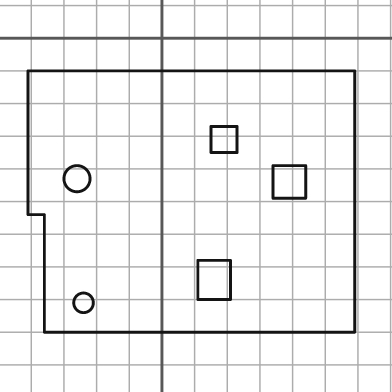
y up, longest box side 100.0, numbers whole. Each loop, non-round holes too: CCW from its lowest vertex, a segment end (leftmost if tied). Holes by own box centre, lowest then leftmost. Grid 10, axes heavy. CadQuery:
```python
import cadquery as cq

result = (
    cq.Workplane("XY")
    .moveTo(-36.0, -90.0)
    .lineTo(59.0, -90.0)
    .lineTo(59.0, -10.0)
    .lineTo(-41.0, -10.0)
    .lineTo(-41.0, -54.0)
    .lineTo(-36.0, -54.0)
    .close()
    .moveTo(-24.0, -81.0)
    .circle(3.0)
    .moveTo(11.0, -80.0)
    .lineTo(21.0, -80.0)
    .lineTo(21.0, -68.0)
    .lineTo(11.0, -68.0)
    .close()
    .moveTo(34.0, -49.0)
    .lineTo(44.0, -49.0)
    .lineTo(44.0, -39.0)
    .lineTo(34.0, -39.0)
    .close()
    .moveTo(-26.0, -43.0)
    .circle(4.0)
    .moveTo(15.0, -35.0)
    .lineTo(23.0, -35.0)
    .lineTo(23.0, -27.0)
    .lineTo(15.0, -27.0)
    .close()
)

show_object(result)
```